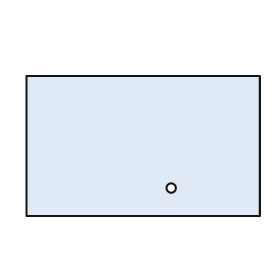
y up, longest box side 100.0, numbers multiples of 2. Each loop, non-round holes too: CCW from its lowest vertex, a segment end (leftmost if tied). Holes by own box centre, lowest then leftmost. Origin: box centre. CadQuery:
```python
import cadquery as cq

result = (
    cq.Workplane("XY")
    .moveTo(-50.0, -30.0)
    .lineTo(50.0, -30.0)
    .lineTo(50.0, 30.0)
    .lineTo(-50.0, 30.0)
    .close()
    .moveTo(12.0, -18.0)
    .circle(2.0)
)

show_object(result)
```